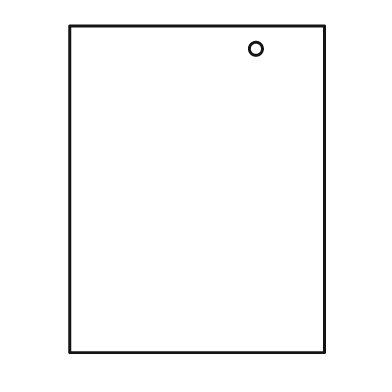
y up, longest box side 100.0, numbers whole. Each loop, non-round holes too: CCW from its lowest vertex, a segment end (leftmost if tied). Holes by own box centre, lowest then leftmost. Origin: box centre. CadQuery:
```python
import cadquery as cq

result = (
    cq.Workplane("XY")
    .moveTo(-39.0, -50.0)
    .lineTo(39.0, -50.0)
    .lineTo(39.0, 50.0)
    .lineTo(-39.0, 50.0)
    .close()
    .moveTo(18.0, 43.0)
    .circle(2.0)
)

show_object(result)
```